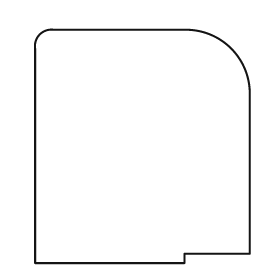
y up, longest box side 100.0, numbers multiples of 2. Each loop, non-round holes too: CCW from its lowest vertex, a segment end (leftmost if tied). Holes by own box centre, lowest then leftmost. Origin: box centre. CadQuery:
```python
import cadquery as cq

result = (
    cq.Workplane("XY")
    .moveTo(-46.0, -50.0)
    .lineTo(18.0, -50.0)
    .lineTo(18.0, -46.0)
    .lineTo(46.0, -46.0)
    .lineTo(46.0, 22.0)
    .threePointArc((38.0, 42.0), (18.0, 50.0))
    .lineTo(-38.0, 50.0)
    .threePointArc((-44.0, 48.0), (-46.0, 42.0))
    .close()
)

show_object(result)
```